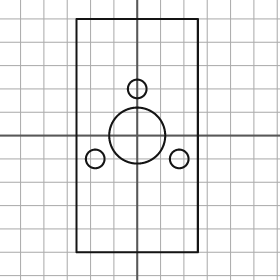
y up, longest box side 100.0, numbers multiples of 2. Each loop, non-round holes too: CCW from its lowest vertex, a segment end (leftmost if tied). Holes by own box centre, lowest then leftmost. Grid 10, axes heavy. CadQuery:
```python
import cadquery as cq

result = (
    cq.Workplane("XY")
    .moveTo(-26.0, -50.0)
    .lineTo(26.0, -50.0)
    .lineTo(26.0, 50.0)
    .lineTo(-26.0, 50.0)
    .close()
    .moveTo(-18.0, -10.0)
    .circle(4.0)
    .moveTo(18.0, -10.0)
    .circle(4.0)
    .moveTo(0.0, 0.0)
    .circle(12.0)
    .moveTo(0.0, 20.0)
    .circle(4.0)
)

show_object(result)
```